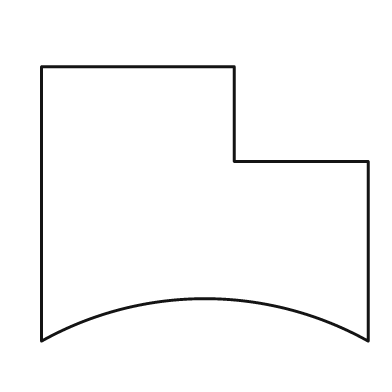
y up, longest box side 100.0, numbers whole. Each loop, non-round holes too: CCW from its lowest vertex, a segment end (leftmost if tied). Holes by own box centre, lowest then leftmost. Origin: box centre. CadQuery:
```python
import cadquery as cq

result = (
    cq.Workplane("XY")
    .moveTo(-50.0, -42.0)
    .threePointArc((0.0, -29.0), (50.0, -42.0))
    .lineTo(50.0, 13.0)
    .lineTo(9.0, 13.0)
    .lineTo(9.0, 42.0)
    .lineTo(-50.0, 42.0)
    .close()
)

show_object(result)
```